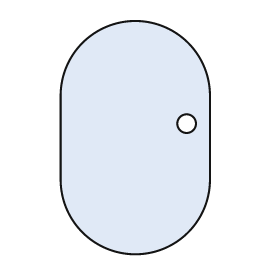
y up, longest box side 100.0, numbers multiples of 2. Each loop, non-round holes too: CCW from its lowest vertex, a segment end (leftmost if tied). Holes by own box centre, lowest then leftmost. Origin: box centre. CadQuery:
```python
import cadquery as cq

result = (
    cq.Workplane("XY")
    .moveTo(-32.0, -18.0)
    .threePointArc((0.0, -50.0), (32.0, -18.0))
    .lineTo(32.0, 18.0)
    .threePointArc((0.0, 50.0), (-32.0, 18.0))
    .close()
    .moveTo(22.0, 6.0)
    .circle(4.0)
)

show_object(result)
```